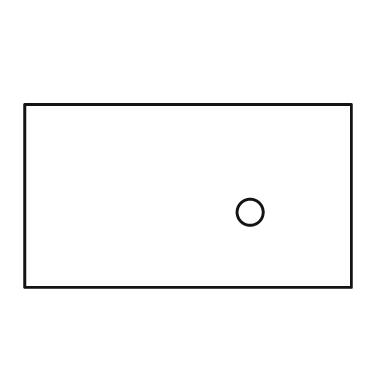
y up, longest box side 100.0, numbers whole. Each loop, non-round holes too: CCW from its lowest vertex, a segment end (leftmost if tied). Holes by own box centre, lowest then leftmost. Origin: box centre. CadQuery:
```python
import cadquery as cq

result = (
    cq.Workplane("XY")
    .moveTo(-50.0, -28.0)
    .lineTo(50.0, -28.0)
    .lineTo(50.0, 28.0)
    .lineTo(-50.0, 28.0)
    .close()
    .moveTo(19.0, -5.0)
    .circle(4.0)
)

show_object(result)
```